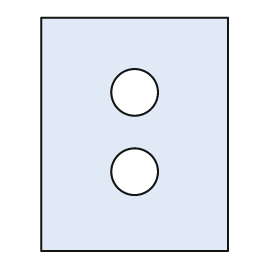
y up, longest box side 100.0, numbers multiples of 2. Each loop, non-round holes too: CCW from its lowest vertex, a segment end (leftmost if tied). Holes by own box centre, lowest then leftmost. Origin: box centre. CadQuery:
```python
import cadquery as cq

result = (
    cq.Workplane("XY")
    .moveTo(-40.0, -50.0)
    .lineTo(40.0, -50.0)
    .lineTo(40.0, 50.0)
    .lineTo(-40.0, 50.0)
    .close()
    .moveTo(0.0, -16.0)
    .circle(10.0)
    .moveTo(0.0, 18.0)
    .circle(10.0)
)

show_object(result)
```